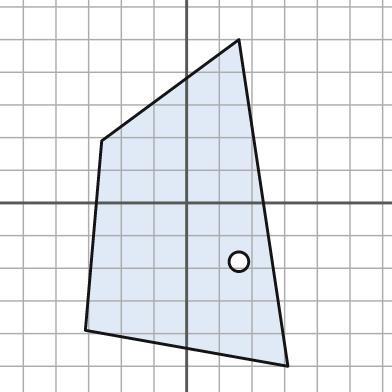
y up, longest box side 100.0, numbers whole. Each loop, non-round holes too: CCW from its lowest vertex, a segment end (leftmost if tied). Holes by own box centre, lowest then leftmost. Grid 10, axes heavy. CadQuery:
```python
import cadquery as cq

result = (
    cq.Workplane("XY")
    .moveTo(31.0, -50.0)
    .lineTo(16.0, 50.0)
    .lineTo(-26.0, 19.0)
    .lineTo(-31.0, -39.0)
    .close()
    .moveTo(16.0, -18.0)
    .circle(3.0)
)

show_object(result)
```